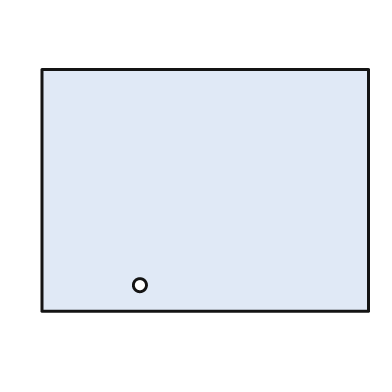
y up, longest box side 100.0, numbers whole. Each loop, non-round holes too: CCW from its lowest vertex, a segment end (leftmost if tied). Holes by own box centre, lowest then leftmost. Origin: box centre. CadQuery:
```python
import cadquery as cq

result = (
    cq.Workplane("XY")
    .moveTo(-50.0, -37.0)
    .lineTo(50.0, -37.0)
    .lineTo(50.0, 37.0)
    .lineTo(-50.0, 37.0)
    .close()
    .moveTo(-20.0, -29.0)
    .circle(2.0)
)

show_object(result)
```